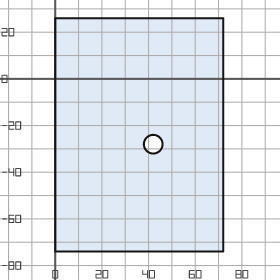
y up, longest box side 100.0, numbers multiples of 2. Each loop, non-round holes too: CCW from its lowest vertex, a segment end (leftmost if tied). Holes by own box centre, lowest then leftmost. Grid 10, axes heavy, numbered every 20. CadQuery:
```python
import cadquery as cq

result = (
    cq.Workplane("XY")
    .moveTo(0.0, -74.0)
    .lineTo(72.0, -74.0)
    .lineTo(72.0, 26.0)
    .lineTo(0.0, 26.0)
    .close()
    .moveTo(42.0, -28.0)
    .circle(4.0)
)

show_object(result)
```